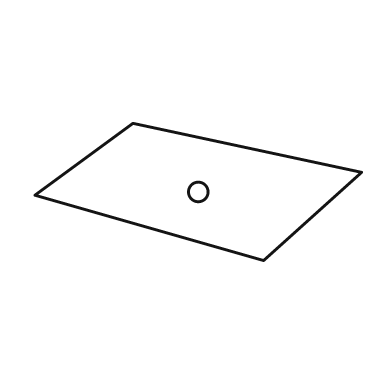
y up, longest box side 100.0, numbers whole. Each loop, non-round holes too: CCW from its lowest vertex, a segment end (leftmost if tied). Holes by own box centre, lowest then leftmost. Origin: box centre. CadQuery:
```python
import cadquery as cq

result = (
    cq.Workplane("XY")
    .moveTo(20.0, -21.0)
    .lineTo(50.0, 6.0)
    .lineTo(-20.0, 21.0)
    .lineTo(-50.0, -1.0)
    .close()
    .moveTo(0.0, 0.0)
    .circle(3.0)
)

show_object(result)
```